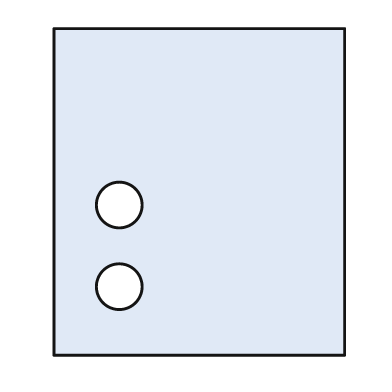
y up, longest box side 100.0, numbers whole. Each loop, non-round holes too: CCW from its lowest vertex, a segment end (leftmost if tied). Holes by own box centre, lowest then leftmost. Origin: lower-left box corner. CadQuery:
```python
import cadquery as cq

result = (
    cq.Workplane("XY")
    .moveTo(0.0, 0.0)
    .lineTo(89.0, 0.0)
    .lineTo(89.0, 100.0)
    .lineTo(0.0, 100.0)
    .close()
    .moveTo(20.0, 21.0)
    .circle(7.0)
    .moveTo(20.0, 46.0)
    .circle(7.0)
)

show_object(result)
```